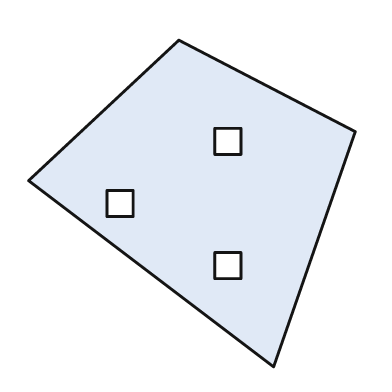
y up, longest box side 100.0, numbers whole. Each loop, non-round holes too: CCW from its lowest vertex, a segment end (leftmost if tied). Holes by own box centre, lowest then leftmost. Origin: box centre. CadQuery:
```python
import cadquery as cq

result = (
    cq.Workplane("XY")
    .moveTo(25.0, -50.0)
    .lineTo(50.0, 22.0)
    .lineTo(-4.0, 50.0)
    .lineTo(-50.0, 7.0)
    .close()
    .moveTo(7.0, -23.0)
    .lineTo(15.0, -23.0)
    .lineTo(15.0, -15.0)
    .lineTo(7.0, -15.0)
    .close()
    .moveTo(-26.0, -4.0)
    .lineTo(-18.0, -4.0)
    .lineTo(-18.0, 4.0)
    .lineTo(-26.0, 4.0)
    .close()
    .moveTo(7.0, 15.0)
    .lineTo(15.0, 15.0)
    .lineTo(15.0, 23.0)
    .lineTo(7.0, 23.0)
    .close()
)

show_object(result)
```